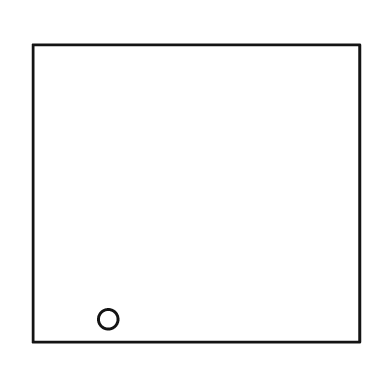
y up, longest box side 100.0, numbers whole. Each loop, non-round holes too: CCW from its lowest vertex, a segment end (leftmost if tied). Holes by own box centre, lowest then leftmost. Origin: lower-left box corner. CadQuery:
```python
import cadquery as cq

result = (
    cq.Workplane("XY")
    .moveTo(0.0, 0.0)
    .lineTo(100.0, 0.0)
    .lineTo(100.0, 91.0)
    .lineTo(0.0, 91.0)
    .close()
    .moveTo(23.0, 7.0)
    .circle(3.0)
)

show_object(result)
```